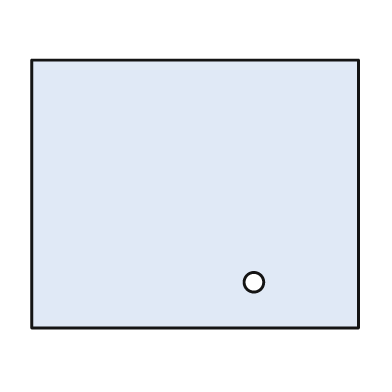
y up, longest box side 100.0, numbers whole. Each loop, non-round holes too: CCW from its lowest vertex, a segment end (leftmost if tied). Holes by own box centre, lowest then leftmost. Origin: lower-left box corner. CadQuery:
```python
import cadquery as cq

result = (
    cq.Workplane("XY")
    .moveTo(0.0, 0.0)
    .lineTo(100.0, 0.0)
    .lineTo(100.0, 82.0)
    .lineTo(0.0, 82.0)
    .close()
    .moveTo(68.0, 14.0)
    .circle(3.0)
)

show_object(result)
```